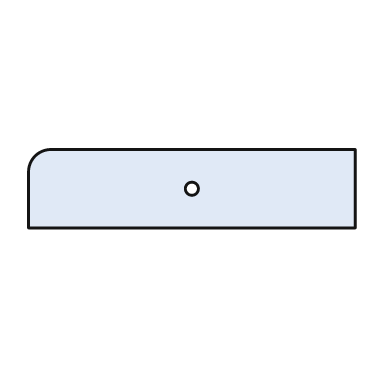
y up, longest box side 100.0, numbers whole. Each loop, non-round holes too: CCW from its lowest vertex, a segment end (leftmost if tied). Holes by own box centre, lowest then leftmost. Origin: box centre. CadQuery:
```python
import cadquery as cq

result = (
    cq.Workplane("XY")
    .moveTo(-50.0, -12.0)
    .lineTo(50.0, -12.0)
    .lineTo(50.0, 12.0)
    .lineTo(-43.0, 12.0)
    .threePointArc((-48.0, 10.0), (-50.0, 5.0))
    .close()
    .moveTo(0.0, 0.0)
    .circle(2.0)
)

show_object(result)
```